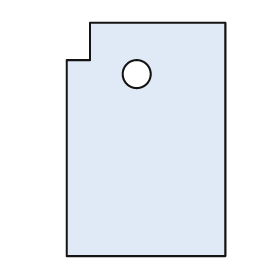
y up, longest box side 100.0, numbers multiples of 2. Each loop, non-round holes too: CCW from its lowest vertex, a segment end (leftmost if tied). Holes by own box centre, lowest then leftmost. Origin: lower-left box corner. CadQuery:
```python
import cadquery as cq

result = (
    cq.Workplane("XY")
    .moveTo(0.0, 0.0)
    .lineTo(68.0, 0.0)
    .lineTo(68.0, 100.0)
    .lineTo(10.0, 100.0)
    .lineTo(10.0, 84.0)
    .lineTo(0.0, 84.0)
    .close()
    .moveTo(30.0, 78.0)
    .circle(6.0)
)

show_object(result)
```